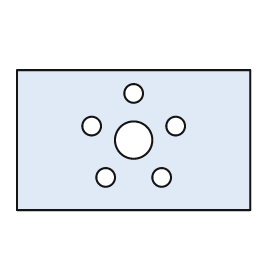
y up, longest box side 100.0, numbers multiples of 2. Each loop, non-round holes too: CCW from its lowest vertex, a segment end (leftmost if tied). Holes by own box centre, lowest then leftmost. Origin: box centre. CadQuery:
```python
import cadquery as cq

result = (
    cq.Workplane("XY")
    .moveTo(-50.0, -30.0)
    .lineTo(50.0, -30.0)
    .lineTo(50.0, 30.0)
    .lineTo(-50.0, 30.0)
    .close()
    .moveTo(-12.0, -16.0)
    .circle(4.0)
    .moveTo(12.0, -16.0)
    .circle(4.0)
    .moveTo(0.0, 0.0)
    .circle(8.0)
    .moveTo(-18.0, 6.0)
    .circle(4.0)
    .moveTo(18.0, 6.0)
    .circle(4.0)
    .moveTo(0.0, 20.0)
    .circle(4.0)
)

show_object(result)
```